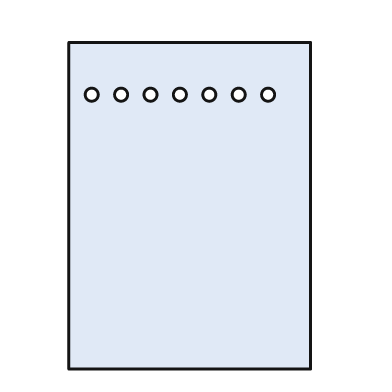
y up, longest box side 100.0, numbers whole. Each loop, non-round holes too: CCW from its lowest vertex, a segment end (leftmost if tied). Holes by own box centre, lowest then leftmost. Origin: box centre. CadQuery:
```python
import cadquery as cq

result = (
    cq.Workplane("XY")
    .moveTo(-37.0, -50.0)
    .lineTo(37.0, -50.0)
    .lineTo(37.0, 50.0)
    .lineTo(-37.0, 50.0)
    .close()
    .moveTo(-30.0, 34.0)
    .circle(2.0)
    .moveTo(-21.0, 34.0)
    .circle(2.0)
    .moveTo(-12.0, 34.0)
    .circle(2.0)
    .moveTo(-3.0, 34.0)
    .circle(2.0)
    .moveTo(6.0, 34.0)
    .circle(2.0)
    .moveTo(15.0, 34.0)
    .circle(2.0)
    .moveTo(24.0, 34.0)
    .circle(2.0)
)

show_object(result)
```